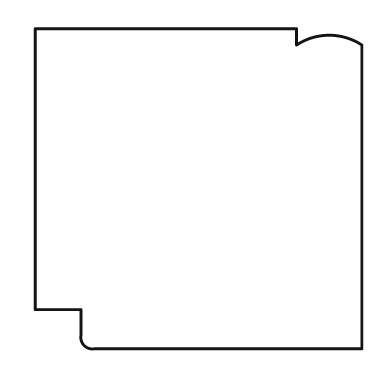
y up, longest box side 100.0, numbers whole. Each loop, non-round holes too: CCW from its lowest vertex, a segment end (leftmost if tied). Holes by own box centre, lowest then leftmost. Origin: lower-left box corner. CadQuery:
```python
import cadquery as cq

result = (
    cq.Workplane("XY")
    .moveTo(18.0, 0.0)
    .lineTo(100.0, 0.0)
    .lineTo(100.0, 93.0)
    .threePointArc((90.0, 96.0), (80.0, 93.0))
    .lineTo(80.0, 98.0)
    .lineTo(0.0, 98.0)
    .lineTo(0.0, 12.0)
    .lineTo(14.0, 12.0)
    .lineTo(14.0, 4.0)
    .threePointArc((15.0, 1.0), (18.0, 0.0))
    .close()
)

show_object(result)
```